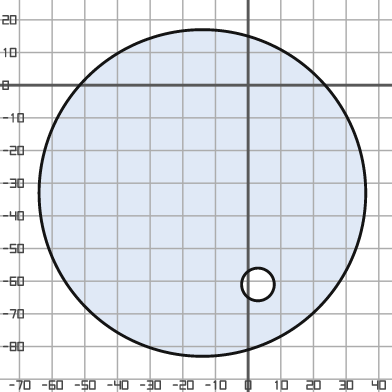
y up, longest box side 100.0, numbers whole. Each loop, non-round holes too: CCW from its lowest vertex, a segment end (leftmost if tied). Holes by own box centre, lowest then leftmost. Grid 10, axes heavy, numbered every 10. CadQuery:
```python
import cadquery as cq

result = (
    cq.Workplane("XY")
    .moveTo(-14.0, -33.0)
    .circle(50.0)
    .moveTo(3.0, -61.0)
    .circle(5.0)
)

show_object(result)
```